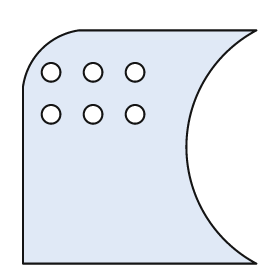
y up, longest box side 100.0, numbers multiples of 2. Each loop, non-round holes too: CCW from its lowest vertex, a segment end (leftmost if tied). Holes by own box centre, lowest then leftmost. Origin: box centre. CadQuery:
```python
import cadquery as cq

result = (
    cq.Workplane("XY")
    .moveTo(-50.0, -50.0)
    .lineTo(50.0, -50.0)
    .threePointArc((20.0, 0.0), (50.0, 50.0))
    .lineTo(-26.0, 50.0)
    .threePointArc((-42.0, 42.0), (-50.0, 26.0))
    .close()
    .moveTo(-38.0, 14.0)
    .circle(4.0)
    .moveTo(-20.0, 14.0)
    .circle(4.0)
    .moveTo(-2.0, 14.0)
    .circle(4.0)
    .moveTo(-38.0, 32.0)
    .circle(4.0)
    .moveTo(-20.0, 32.0)
    .circle(4.0)
    .moveTo(-2.0, 32.0)
    .circle(4.0)
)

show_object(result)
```